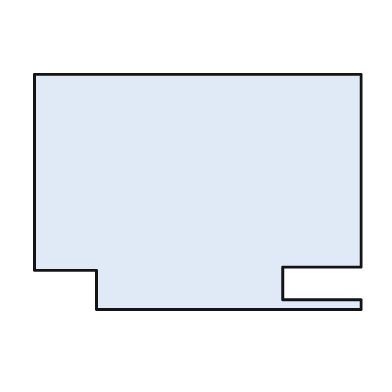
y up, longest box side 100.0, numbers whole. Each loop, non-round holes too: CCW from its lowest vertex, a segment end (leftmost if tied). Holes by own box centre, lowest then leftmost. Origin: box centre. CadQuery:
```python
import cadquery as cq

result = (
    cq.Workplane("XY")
    .moveTo(-31.0, -36.0)
    .lineTo(50.0, -36.0)
    .lineTo(50.0, -33.0)
    .lineTo(26.0, -33.0)
    .lineTo(26.0, -23.0)
    .lineTo(50.0, -23.0)
    .lineTo(50.0, 36.0)
    .lineTo(-50.0, 36.0)
    .lineTo(-50.0, -24.0)
    .lineTo(-31.0, -24.0)
    .close()
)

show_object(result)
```